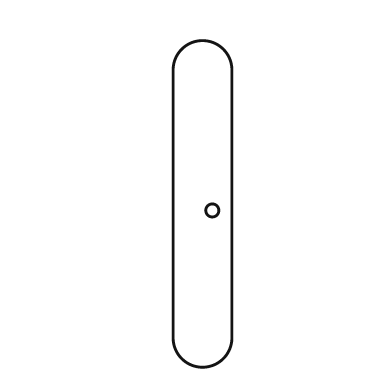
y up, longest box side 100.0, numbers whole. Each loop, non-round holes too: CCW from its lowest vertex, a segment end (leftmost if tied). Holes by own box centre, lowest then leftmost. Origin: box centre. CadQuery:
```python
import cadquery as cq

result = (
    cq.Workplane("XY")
    .moveTo(-9.0, -41.0)
    .threePointArc((0.0, -50.0), (9.0, -41.0))
    .lineTo(9.0, 41.0)
    .threePointArc((0.0, 50.0), (-9.0, 41.0))
    .close()
    .moveTo(3.0, -2.0)
    .circle(2.0)
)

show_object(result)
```